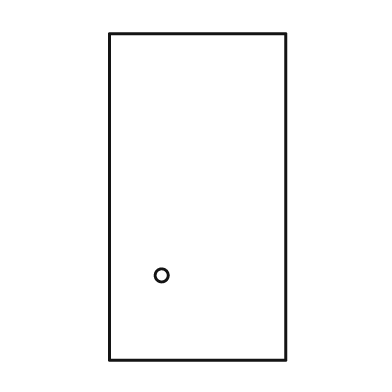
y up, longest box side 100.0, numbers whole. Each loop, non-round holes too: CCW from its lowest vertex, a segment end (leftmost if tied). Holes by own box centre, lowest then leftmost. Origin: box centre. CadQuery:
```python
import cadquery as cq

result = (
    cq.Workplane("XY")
    .moveTo(-27.0, -50.0)
    .lineTo(27.0, -50.0)
    .lineTo(27.0, 50.0)
    .lineTo(-27.0, 50.0)
    .close()
    .moveTo(-11.0, -24.0)
    .circle(2.0)
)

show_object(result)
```